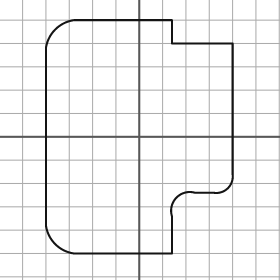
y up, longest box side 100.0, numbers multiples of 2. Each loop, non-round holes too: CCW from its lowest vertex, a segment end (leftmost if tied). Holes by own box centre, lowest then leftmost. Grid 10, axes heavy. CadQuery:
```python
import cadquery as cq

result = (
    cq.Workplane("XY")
    .moveTo(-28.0, -50.0)
    .lineTo(14.0, -50.0)
    .lineTo(14.0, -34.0)
    .threePointArc((16.0, -26.0), (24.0, -24.0))
    .lineTo(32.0, -24.0)
    .threePointArc((38.0, -22.0), (40.0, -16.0))
    .lineTo(40.0, 40.0)
    .lineTo(14.0, 40.0)
    .lineTo(14.0, 50.0)
    .lineTo(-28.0, 50.0)
    .threePointArc((-36.0, 46.0), (-40.0, 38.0))
    .lineTo(-40.0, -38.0)
    .threePointArc((-36.0, -46.0), (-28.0, -50.0))
    .close()
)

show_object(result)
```